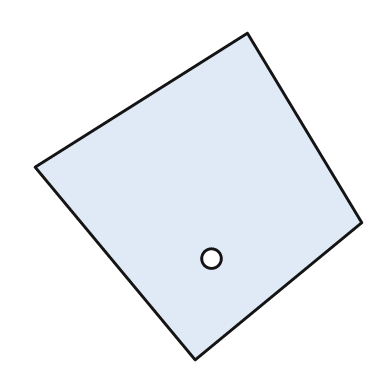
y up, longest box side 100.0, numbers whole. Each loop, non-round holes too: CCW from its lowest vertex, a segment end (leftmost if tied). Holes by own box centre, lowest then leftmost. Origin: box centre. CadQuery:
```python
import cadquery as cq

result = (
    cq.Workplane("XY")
    .moveTo(-1.0, -50.0)
    .lineTo(50.0, -8.0)
    .lineTo(15.0, 50.0)
    .lineTo(-50.0, 9.0)
    .close()
    .moveTo(4.0, -19.0)
    .circle(3.0)
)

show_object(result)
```